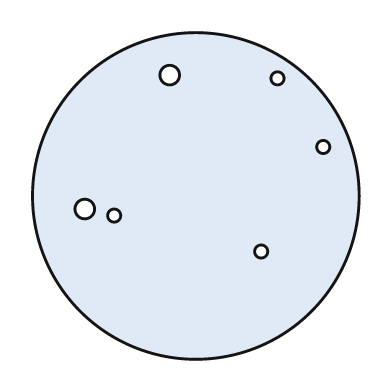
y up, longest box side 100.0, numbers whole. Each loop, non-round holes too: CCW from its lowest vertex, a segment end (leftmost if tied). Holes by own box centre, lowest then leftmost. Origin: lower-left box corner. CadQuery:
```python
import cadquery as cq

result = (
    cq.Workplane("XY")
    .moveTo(50.0, 50.0)
    .circle(50.0)
    .moveTo(70.0, 33.0)
    .circle(2.0)
    .moveTo(25.0, 44.0)
    .circle(2.0)
    .moveTo(16.0, 46.0)
    .circle(3.0)
    .moveTo(89.0, 65.0)
    .circle(2.0)
    .moveTo(75.0, 86.0)
    .circle(2.0)
    .moveTo(42.0, 87.0)
    .circle(3.0)
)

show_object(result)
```